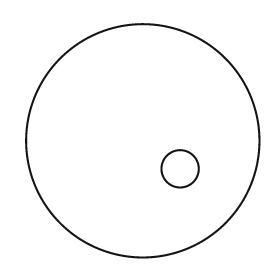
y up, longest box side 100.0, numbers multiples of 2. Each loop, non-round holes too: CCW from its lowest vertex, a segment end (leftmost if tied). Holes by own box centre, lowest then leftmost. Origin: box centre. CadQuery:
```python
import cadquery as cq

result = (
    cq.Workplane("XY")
    .moveTo(0.0, 0.0)
    .circle(50.0)
    .moveTo(16.0, -12.0)
    .circle(8.0)
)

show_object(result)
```